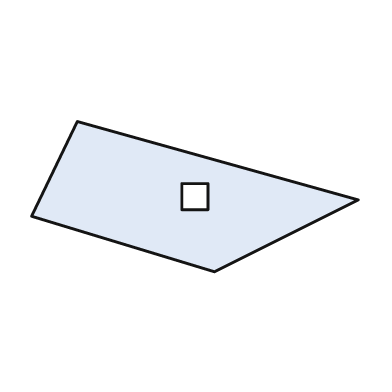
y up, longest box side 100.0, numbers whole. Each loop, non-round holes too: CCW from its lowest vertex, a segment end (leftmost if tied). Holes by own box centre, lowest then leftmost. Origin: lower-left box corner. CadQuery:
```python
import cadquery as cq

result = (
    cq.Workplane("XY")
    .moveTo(56.0, 0.0)
    .lineTo(100.0, 22.0)
    .lineTo(14.0, 46.0)
    .lineTo(0.0, 17.0)
    .close()
    .moveTo(46.0, 19.0)
    .lineTo(54.0, 19.0)
    .lineTo(54.0, 27.0)
    .lineTo(46.0, 27.0)
    .close()
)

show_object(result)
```